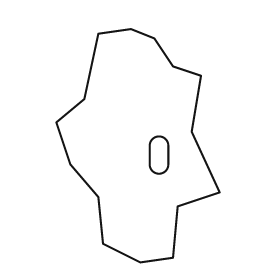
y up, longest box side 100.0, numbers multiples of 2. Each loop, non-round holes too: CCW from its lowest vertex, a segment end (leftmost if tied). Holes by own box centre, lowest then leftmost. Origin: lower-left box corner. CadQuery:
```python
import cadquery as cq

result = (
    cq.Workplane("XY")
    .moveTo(36.0, 0.0)
    .lineTo(50.0, 2.0)
    .lineTo(52.0, 24.0)
    .lineTo(70.0, 30.0)
    .lineTo(58.0, 56.0)
    .lineTo(62.0, 80.0)
    .lineTo(50.0, 84.0)
    .lineTo(42.0, 96.0)
    .lineTo(32.0, 100.0)
    .lineTo(18.0, 98.0)
    .lineTo(12.0, 70.0)
    .lineTo(0.0, 60.0)
    .lineTo(6.0, 42.0)
    .lineTo(18.0, 28.0)
    .lineTo(20.0, 8.0)
    .close()
    .moveTo(40.0, 42.0)
    .threePointArc((44.0, 38.0), (48.0, 42.0))
    .lineTo(48.0, 50.0)
    .threePointArc((44.0, 54.0), (40.0, 50.0))
    .close()
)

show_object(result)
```